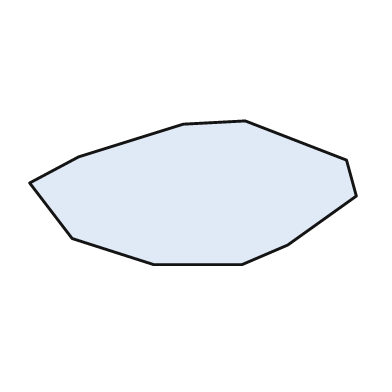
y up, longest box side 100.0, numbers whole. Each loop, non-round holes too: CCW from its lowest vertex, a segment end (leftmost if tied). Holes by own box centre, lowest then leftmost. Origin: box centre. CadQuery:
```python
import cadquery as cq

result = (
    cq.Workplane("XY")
    .moveTo(-12.0, -22.0)
    .lineTo(15.0, -22.0)
    .lineTo(29.0, -16.0)
    .lineTo(50.0, -1.0)
    .lineTo(47.0, 10.0)
    .lineTo(16.0, 22.0)
    .lineTo(-3.0, 21.0)
    .lineTo(-35.0, 11.0)
    .lineTo(-50.0, 3.0)
    .lineTo(-37.0, -14.0)
    .close()
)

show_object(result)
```